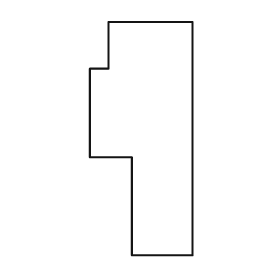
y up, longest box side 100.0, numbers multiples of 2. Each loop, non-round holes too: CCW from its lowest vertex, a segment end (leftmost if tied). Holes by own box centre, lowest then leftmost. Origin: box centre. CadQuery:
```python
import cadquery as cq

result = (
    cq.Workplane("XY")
    .moveTo(-4.0, -50.0)
    .lineTo(22.0, -50.0)
    .lineTo(22.0, 50.0)
    .lineTo(-14.0, 50.0)
    .lineTo(-14.0, 30.0)
    .lineTo(-22.0, 30.0)
    .lineTo(-22.0, -8.0)
    .lineTo(-4.0, -8.0)
    .close()
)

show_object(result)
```